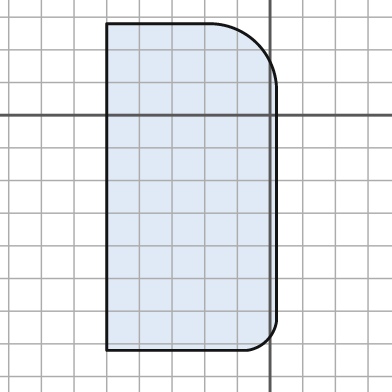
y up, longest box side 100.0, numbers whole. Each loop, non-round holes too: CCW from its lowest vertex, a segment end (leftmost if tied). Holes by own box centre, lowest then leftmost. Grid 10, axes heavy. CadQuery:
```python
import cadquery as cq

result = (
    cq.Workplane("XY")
    .moveTo(-50.0, -72.0)
    .lineTo(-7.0, -72.0)
    .threePointArc((-1.0, -69.0), (2.0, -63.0))
    .lineTo(2.0, 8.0)
    .threePointArc((-4.0, 22.0), (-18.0, 28.0))
    .lineTo(-50.0, 28.0)
    .close()
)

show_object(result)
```